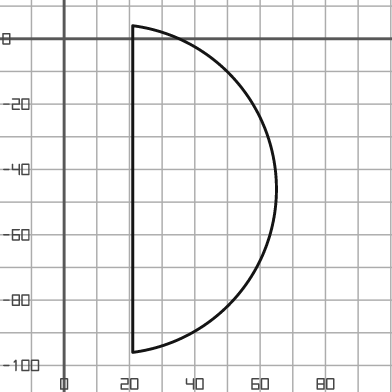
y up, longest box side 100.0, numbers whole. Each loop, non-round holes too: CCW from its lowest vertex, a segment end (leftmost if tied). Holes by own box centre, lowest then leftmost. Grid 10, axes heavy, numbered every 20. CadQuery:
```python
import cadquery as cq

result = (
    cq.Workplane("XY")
    .moveTo(21.0, -96.0)
    .threePointArc((65.0, -46.0), (21.0, 4.0))
    .close()
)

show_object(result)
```